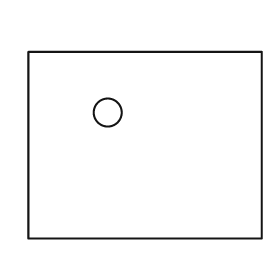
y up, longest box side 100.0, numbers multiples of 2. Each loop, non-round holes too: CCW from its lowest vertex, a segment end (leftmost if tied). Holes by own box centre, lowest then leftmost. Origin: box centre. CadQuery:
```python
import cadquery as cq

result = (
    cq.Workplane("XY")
    .moveTo(-50.0, -40.0)
    .lineTo(50.0, -40.0)
    .lineTo(50.0, 40.0)
    .lineTo(-50.0, 40.0)
    .close()
    .moveTo(-16.0, 14.0)
    .circle(6.0)
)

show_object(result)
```